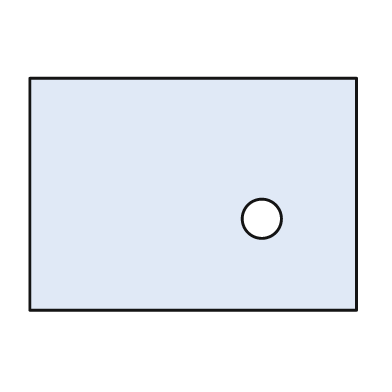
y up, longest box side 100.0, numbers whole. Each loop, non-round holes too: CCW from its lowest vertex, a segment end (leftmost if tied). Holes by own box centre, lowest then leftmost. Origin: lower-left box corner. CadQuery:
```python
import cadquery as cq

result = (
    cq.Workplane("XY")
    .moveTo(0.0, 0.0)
    .lineTo(100.0, 0.0)
    .lineTo(100.0, 71.0)
    .lineTo(0.0, 71.0)
    .close()
    .moveTo(71.0, 28.0)
    .circle(6.0)
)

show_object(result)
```